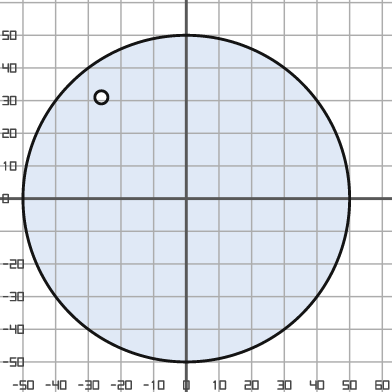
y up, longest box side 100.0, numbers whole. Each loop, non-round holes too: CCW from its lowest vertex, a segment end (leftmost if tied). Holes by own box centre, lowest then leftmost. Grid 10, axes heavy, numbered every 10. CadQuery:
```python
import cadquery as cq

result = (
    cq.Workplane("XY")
    .moveTo(0.0, 0.0)
    .circle(50.0)
    .moveTo(-26.0, 31.0)
    .circle(2.0)
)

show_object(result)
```